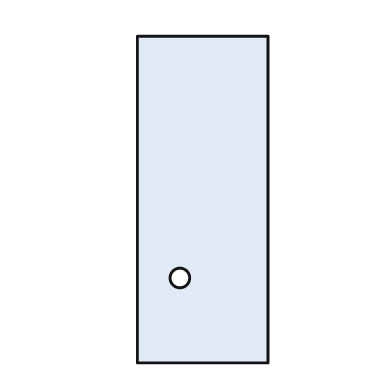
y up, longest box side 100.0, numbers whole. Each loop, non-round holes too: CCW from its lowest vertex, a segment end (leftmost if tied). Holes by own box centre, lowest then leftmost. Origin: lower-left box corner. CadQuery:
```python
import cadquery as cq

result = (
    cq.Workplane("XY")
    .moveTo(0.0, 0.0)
    .lineTo(40.0, 0.0)
    .lineTo(40.0, 100.0)
    .lineTo(0.0, 100.0)
    .close()
    .moveTo(13.0, 26.0)
    .circle(3.0)
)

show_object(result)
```